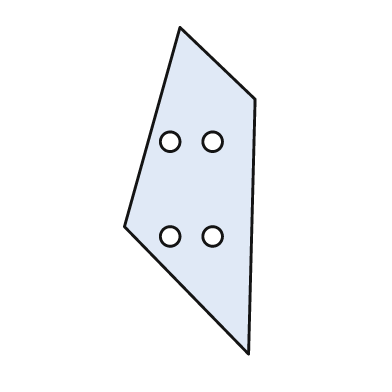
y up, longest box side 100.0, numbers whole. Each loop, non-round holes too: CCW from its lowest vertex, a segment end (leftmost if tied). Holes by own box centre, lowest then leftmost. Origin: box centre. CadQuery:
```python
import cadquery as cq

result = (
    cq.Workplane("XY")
    .moveTo(18.0, -50.0)
    .lineTo(20.0, 28.0)
    .lineTo(-3.0, 50.0)
    .lineTo(-20.0, -11.0)
    .close()
    .moveTo(-6.0, -14.0)
    .circle(3.0)
    .moveTo(7.0, -14.0)
    .circle(3.0)
    .moveTo(-6.0, 15.0)
    .circle(3.0)
    .moveTo(7.0, 15.0)
    .circle(3.0)
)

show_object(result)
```